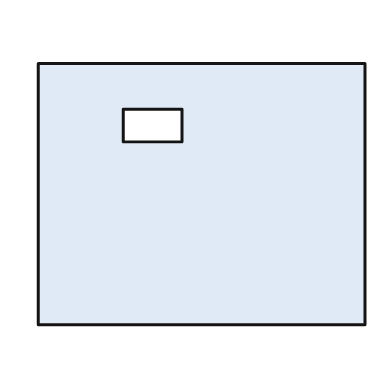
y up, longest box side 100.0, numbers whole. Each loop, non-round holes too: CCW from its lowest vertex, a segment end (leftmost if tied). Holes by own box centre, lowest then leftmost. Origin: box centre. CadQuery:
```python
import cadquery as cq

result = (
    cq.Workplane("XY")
    .moveTo(-50.0, -40.0)
    .lineTo(50.0, -40.0)
    .lineTo(50.0, 40.0)
    .lineTo(-50.0, 40.0)
    .close()
    .moveTo(-24.0, 16.0)
    .lineTo(-6.0, 16.0)
    .lineTo(-6.0, 26.0)
    .lineTo(-24.0, 26.0)
    .close()
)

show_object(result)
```